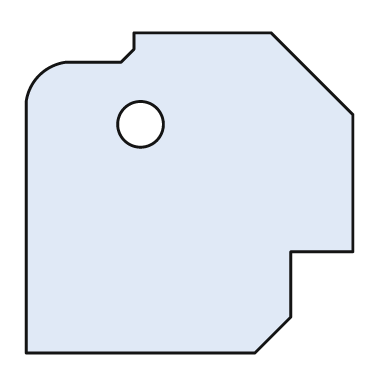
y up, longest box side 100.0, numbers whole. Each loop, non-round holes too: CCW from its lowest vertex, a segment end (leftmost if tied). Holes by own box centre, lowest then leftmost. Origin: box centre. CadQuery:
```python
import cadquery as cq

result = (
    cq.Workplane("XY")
    .moveTo(-50.0, -49.0)
    .lineTo(20.0, -49.0)
    .lineTo(31.0, -38.0)
    .lineTo(31.0, -18.0)
    .lineTo(50.0, -18.0)
    .lineTo(50.0, 24.0)
    .lineTo(25.0, 49.0)
    .lineTo(-17.0, 49.0)
    .lineTo(-17.0, 44.0)
    .lineTo(-21.0, 40.0)
    .lineTo(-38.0, 40.0)
    .threePointArc((-46.0, 36.0), (-50.0, 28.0))
    .close()
    .moveTo(-15.0, 21.0)
    .circle(7.0)
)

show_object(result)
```